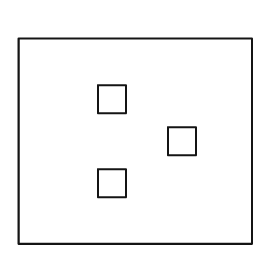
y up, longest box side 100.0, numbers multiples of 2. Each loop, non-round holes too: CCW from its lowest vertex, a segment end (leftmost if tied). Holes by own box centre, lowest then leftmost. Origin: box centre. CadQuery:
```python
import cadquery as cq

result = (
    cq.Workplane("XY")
    .moveTo(-50.0, -44.0)
    .lineTo(50.0, -44.0)
    .lineTo(50.0, 44.0)
    .lineTo(-50.0, 44.0)
    .close()
    .moveTo(-16.0, -24.0)
    .lineTo(-4.0, -24.0)
    .lineTo(-4.0, -12.0)
    .lineTo(-16.0, -12.0)
    .close()
    .moveTo(14.0, -6.0)
    .lineTo(26.0, -6.0)
    .lineTo(26.0, 6.0)
    .lineTo(14.0, 6.0)
    .close()
    .moveTo(-16.0, 12.0)
    .lineTo(-4.0, 12.0)
    .lineTo(-4.0, 24.0)
    .lineTo(-16.0, 24.0)
    .close()
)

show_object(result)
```